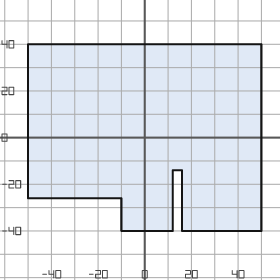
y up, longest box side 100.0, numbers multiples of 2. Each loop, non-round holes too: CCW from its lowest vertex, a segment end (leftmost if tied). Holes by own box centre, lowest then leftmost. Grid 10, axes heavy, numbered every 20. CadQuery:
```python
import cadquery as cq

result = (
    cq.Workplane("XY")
    .moveTo(-10.0, -40.0)
    .lineTo(12.0, -40.0)
    .lineTo(12.0, -14.0)
    .lineTo(16.0, -14.0)
    .lineTo(16.0, -40.0)
    .lineTo(50.0, -40.0)
    .lineTo(50.0, 40.0)
    .lineTo(-50.0, 40.0)
    .lineTo(-50.0, -26.0)
    .lineTo(-10.0, -26.0)
    .close()
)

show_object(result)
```